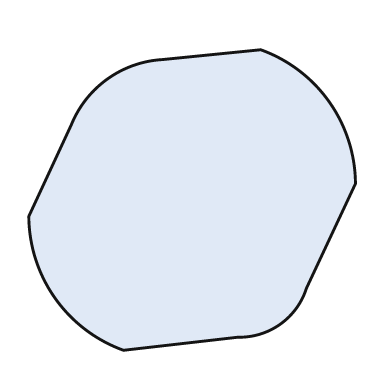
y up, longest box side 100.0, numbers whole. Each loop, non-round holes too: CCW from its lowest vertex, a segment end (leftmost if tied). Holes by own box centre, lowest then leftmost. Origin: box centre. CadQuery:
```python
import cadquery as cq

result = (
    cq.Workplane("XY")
    .moveTo(-21.0, -46.0)
    .lineTo(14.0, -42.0)
    .threePointArc((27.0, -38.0), (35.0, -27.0))
    .lineTo(50.0, 5.0)
    .threePointArc((42.0, 30.0), (21.0, 46.0))
    .lineTo(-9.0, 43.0)
    .threePointArc((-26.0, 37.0), (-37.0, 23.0))
    .lineTo(-50.0, -5.0)
    .threePointArc((-42.0, -30.0), (-21.0, -46.0))
    .close()
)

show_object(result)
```